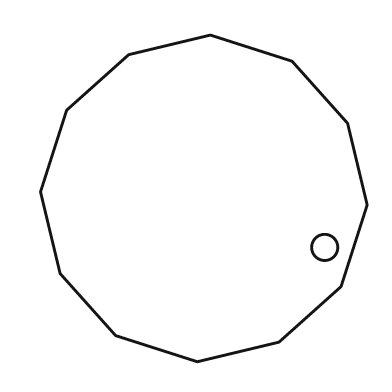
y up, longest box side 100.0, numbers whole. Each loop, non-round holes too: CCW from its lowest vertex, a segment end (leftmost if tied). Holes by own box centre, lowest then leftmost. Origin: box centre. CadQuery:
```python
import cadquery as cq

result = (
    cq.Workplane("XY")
    .moveTo(-2.0, -50.0)
    .lineTo(23.0, -44.0)
    .lineTo(42.0, -27.0)
    .lineTo(50.0, -2.0)
    .lineTo(44.0, 23.0)
    .lineTo(27.0, 42.0)
    .lineTo(2.0, 50.0)
    .lineTo(-23.0, 44.0)
    .lineTo(-42.0, 27.0)
    .lineTo(-50.0, 2.0)
    .lineTo(-44.0, -23.0)
    .lineTo(-27.0, -42.0)
    .close()
    .moveTo(37.0, -15.0)
    .circle(4.0)
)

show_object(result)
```